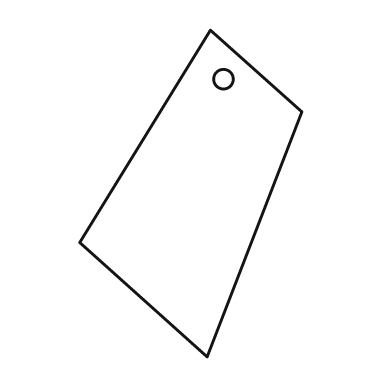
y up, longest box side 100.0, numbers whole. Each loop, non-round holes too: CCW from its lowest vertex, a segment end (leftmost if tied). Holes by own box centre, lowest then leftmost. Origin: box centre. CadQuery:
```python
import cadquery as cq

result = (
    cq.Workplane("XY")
    .moveTo(5.0, -50.0)
    .lineTo(34.0, 25.0)
    .lineTo(6.0, 50.0)
    .lineTo(-34.0, -15.0)
    .close()
    .moveTo(10.0, 35.0)
    .circle(3.0)
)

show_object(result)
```